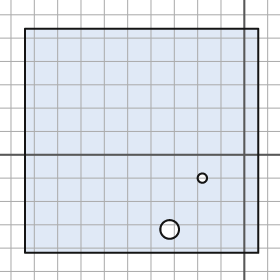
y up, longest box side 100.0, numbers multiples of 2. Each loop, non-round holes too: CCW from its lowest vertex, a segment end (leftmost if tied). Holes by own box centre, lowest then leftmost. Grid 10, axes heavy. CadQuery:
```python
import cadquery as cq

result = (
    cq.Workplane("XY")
    .moveTo(-94.0, -42.0)
    .lineTo(6.0, -42.0)
    .lineTo(6.0, 54.0)
    .lineTo(-94.0, 54.0)
    .close()
    .moveTo(-32.0, -32.0)
    .circle(4.0)
    .moveTo(-18.0, -10.0)
    .circle(2.0)
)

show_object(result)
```